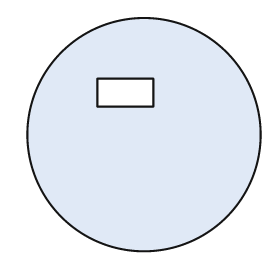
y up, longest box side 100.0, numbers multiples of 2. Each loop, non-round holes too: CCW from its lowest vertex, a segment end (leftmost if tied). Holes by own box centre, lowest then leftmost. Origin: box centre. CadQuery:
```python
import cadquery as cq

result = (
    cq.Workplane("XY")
    .moveTo(0.0, 0.0)
    .circle(50.0)
    .moveTo(-20.0, 12.0)
    .lineTo(4.0, 12.0)
    .lineTo(4.0, 24.0)
    .lineTo(-20.0, 24.0)
    .close()
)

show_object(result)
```